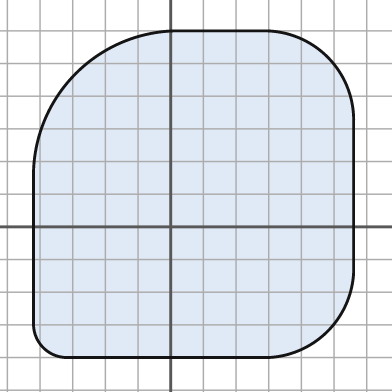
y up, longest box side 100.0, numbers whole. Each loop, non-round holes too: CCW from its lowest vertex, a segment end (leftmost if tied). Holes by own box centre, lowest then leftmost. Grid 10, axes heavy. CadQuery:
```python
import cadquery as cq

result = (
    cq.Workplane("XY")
    .moveTo(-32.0, -40.0)
    .lineTo(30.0, -40.0)
    .threePointArc((48.0, -32.0), (56.0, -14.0))
    .lineTo(56.0, 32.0)
    .threePointArc((48.0, 52.0), (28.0, 60.0))
    .lineTo(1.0, 60.0)
    .threePointArc((-29.0, 47.0), (-42.0, 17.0))
    .lineTo(-42.0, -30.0)
    .threePointArc((-39.0, -37.0), (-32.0, -40.0))
    .close()
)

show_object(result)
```